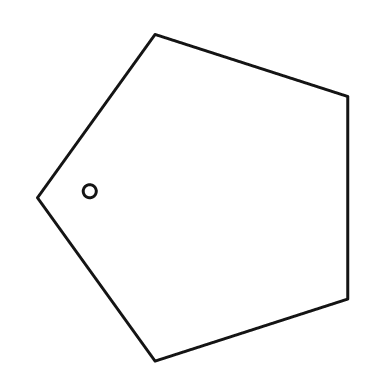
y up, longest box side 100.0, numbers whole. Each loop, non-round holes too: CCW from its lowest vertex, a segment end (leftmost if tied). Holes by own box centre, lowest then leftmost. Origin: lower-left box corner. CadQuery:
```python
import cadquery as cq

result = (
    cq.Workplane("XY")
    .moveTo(36.0, 0.0)
    .lineTo(95.0, 19.0)
    .lineTo(95.0, 81.0)
    .lineTo(36.0, 100.0)
    .lineTo(0.0, 50.0)
    .close()
    .moveTo(16.0, 52.0)
    .circle(2.0)
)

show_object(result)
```